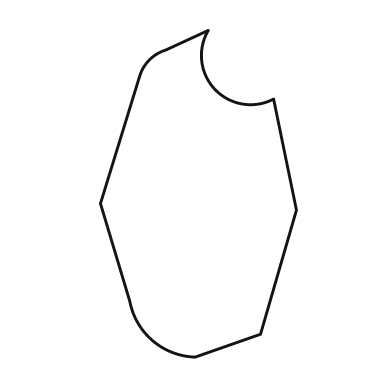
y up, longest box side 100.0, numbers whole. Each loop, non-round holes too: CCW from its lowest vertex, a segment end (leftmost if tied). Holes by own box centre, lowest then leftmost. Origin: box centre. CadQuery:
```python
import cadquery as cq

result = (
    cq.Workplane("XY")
    .moveTo(-1.0, -50.0)
    .lineTo(19.0, -43.0)
    .lineTo(30.0, -5.0)
    .lineTo(23.0, 29.0)
    .threePointArc((5.0, 32.0), (3.0, 50.0))
    .lineTo(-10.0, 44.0)
    .threePointArc((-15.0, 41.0), (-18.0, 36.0))
    .lineTo(-30.0, -3.0)
    .lineTo(-21.0, -33.0)
    .threePointArc((-14.0, -45.0), (-1.0, -50.0))
    .close()
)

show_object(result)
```